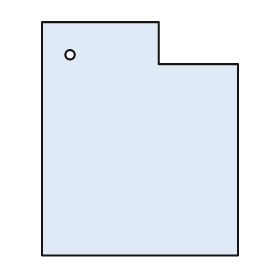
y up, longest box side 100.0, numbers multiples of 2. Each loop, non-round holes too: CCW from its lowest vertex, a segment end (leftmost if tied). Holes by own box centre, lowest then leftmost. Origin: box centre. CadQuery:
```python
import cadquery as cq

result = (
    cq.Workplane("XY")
    .moveTo(-42.0, -50.0)
    .lineTo(42.0, -50.0)
    .lineTo(42.0, 32.0)
    .lineTo(8.0, 32.0)
    .lineTo(8.0, 50.0)
    .lineTo(-42.0, 50.0)
    .close()
    .moveTo(-30.0, 36.0)
    .circle(2.0)
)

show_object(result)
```